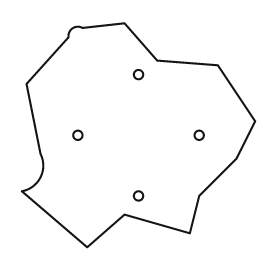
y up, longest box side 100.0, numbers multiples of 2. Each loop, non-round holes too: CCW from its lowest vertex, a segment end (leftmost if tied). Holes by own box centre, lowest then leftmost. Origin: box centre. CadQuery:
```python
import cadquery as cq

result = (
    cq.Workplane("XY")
    .moveTo(-22.0, -48.0)
    .lineTo(-6.0, -34.0)
    .lineTo(22.0, -42.0)
    .lineTo(26.0, -26.0)
    .lineTo(42.0, -10.0)
    .lineTo(50.0, 6.0)
    .lineTo(34.0, 30.0)
    .lineTo(8.0, 32.0)
    .lineTo(-6.0, 48.0)
    .lineTo(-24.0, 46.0)
    .threePointArc((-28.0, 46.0), (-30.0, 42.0))
    .lineTo(-48.0, 22.0)
    .lineTo(-42.0, -8.0)
    .threePointArc((-42.0, -18.0), (-50.0, -24.0))
    .close()
    .moveTo(0.0, -26.0)
    .circle(2.0)
    .moveTo(-26.0, 0.0)
    .circle(2.0)
    .moveTo(26.0, 0.0)
    .circle(2.0)
    .moveTo(0.0, 26.0)
    .circle(2.0)
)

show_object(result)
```